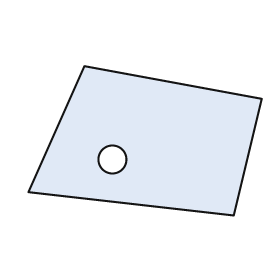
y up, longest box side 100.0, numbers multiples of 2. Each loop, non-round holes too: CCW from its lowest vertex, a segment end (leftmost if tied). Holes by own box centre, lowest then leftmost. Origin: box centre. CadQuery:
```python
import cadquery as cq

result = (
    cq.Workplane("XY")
    .moveTo(38.0, -32.0)
    .lineTo(50.0, 18.0)
    .lineTo(-26.0, 32.0)
    .lineTo(-50.0, -22.0)
    .close()
    .moveTo(-14.0, -8.0)
    .circle(6.0)
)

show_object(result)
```